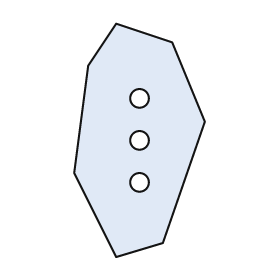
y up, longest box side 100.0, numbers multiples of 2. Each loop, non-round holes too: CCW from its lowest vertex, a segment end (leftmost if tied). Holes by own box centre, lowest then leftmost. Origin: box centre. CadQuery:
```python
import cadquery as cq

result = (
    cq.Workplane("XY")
    .moveTo(-10.0, -50.0)
    .lineTo(10.0, -44.0)
    .lineTo(28.0, 8.0)
    .lineTo(14.0, 42.0)
    .lineTo(-10.0, 50.0)
    .lineTo(-22.0, 32.0)
    .lineTo(-28.0, -14.0)
    .close()
    .moveTo(0.0, -18.0)
    .circle(4.0)
    .moveTo(0.0, 0.0)
    .circle(4.0)
    .moveTo(0.0, 18.0)
    .circle(4.0)
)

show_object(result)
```